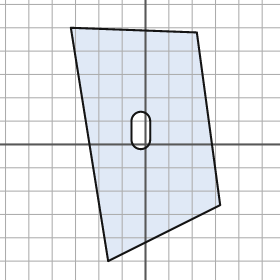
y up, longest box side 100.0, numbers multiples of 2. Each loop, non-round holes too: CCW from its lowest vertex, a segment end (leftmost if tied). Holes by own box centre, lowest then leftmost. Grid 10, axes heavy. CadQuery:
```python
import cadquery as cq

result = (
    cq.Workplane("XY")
    .moveTo(-16.0, -50.0)
    .lineTo(32.0, -26.0)
    .lineTo(22.0, 48.0)
    .lineTo(-32.0, 50.0)
    .close()
    .moveTo(-6.0, 2.0)
    .threePointArc((-2.0, -2.0), (2.0, 2.0))
    .lineTo(2.0, 10.0)
    .threePointArc((-2.0, 14.0), (-6.0, 10.0))
    .close()
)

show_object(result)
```